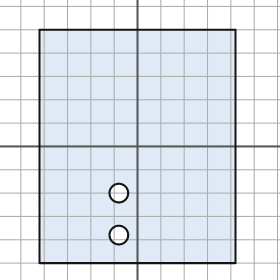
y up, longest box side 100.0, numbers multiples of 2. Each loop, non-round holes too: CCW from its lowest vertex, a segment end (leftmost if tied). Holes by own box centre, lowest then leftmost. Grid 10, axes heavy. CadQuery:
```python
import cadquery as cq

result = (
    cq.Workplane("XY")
    .moveTo(-42.0, -50.0)
    .lineTo(42.0, -50.0)
    .lineTo(42.0, 50.0)
    .lineTo(-42.0, 50.0)
    .close()
    .moveTo(-8.0, -38.0)
    .circle(4.0)
    .moveTo(-8.0, -20.0)
    .circle(4.0)
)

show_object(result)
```